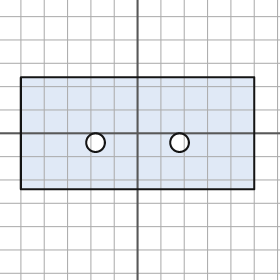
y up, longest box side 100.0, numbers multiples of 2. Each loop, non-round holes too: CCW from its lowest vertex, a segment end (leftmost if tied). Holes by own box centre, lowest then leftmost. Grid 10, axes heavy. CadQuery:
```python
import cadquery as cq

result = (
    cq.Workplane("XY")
    .moveTo(-50.0, -24.0)
    .lineTo(50.0, -24.0)
    .lineTo(50.0, 24.0)
    .lineTo(-50.0, 24.0)
    .close()
    .moveTo(-18.0, -4.0)
    .circle(4.0)
    .moveTo(18.0, -4.0)
    .circle(4.0)
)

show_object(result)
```